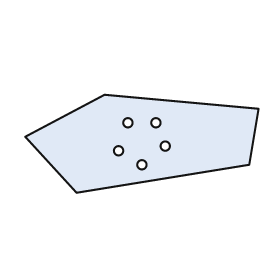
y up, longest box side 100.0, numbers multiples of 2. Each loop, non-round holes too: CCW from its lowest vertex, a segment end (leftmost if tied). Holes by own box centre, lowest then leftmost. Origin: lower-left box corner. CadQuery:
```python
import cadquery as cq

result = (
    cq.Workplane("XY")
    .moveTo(22.0, 0.0)
    .lineTo(96.0, 12.0)
    .lineTo(100.0, 36.0)
    .lineTo(34.0, 42.0)
    .lineTo(0.0, 24.0)
    .close()
    .moveTo(50.0, 12.0)
    .circle(2.0)
    .moveTo(40.0, 18.0)
    .circle(2.0)
    .moveTo(60.0, 20.0)
    .circle(2.0)
    .moveTo(44.0, 30.0)
    .circle(2.0)
    .moveTo(56.0, 30.0)
    .circle(2.0)
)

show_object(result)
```